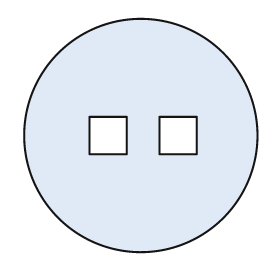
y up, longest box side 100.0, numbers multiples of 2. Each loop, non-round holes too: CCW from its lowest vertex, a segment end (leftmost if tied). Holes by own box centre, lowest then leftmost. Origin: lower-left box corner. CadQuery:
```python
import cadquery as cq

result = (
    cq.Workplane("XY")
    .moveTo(50.0, 50.0)
    .circle(50.0)
    .moveTo(28.0, 42.0)
    .lineTo(44.0, 42.0)
    .lineTo(44.0, 58.0)
    .lineTo(28.0, 58.0)
    .close()
    .moveTo(58.0, 42.0)
    .lineTo(74.0, 42.0)
    .lineTo(74.0, 58.0)
    .lineTo(58.0, 58.0)
    .close()
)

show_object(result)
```